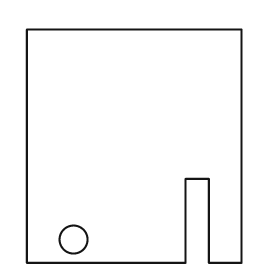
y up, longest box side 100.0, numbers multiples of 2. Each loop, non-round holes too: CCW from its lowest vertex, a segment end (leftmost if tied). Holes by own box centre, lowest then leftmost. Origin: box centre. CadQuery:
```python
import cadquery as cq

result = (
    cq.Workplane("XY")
    .moveTo(-46.0, -50.0)
    .lineTo(22.0, -50.0)
    .lineTo(22.0, -14.0)
    .lineTo(32.0, -14.0)
    .lineTo(32.0, -50.0)
    .lineTo(46.0, -50.0)
    .lineTo(46.0, 50.0)
    .lineTo(-46.0, 50.0)
    .close()
    .moveTo(-26.0, -40.0)
    .circle(6.0)
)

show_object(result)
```